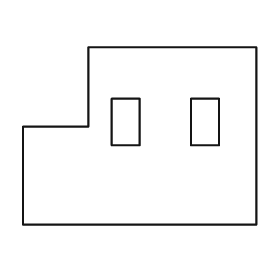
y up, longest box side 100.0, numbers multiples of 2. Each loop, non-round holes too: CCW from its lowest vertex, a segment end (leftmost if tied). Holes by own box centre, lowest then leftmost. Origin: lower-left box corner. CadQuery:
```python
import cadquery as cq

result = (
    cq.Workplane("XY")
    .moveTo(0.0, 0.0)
    .lineTo(100.0, 0.0)
    .lineTo(100.0, 76.0)
    .lineTo(28.0, 76.0)
    .lineTo(28.0, 42.0)
    .lineTo(0.0, 42.0)
    .close()
    .moveTo(38.0, 34.0)
    .lineTo(50.0, 34.0)
    .lineTo(50.0, 54.0)
    .lineTo(38.0, 54.0)
    .close()
    .moveTo(72.0, 34.0)
    .lineTo(84.0, 34.0)
    .lineTo(84.0, 54.0)
    .lineTo(72.0, 54.0)
    .close()
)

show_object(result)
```